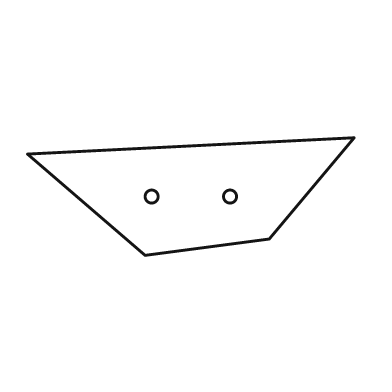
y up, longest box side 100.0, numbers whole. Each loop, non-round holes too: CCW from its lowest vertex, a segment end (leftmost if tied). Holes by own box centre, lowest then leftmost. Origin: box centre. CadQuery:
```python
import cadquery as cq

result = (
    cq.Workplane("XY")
    .moveTo(-14.0, -18.0)
    .lineTo(24.0, -13.0)
    .lineTo(50.0, 18.0)
    .lineTo(-50.0, 13.0)
    .close()
    .moveTo(-12.0, 0.0)
    .circle(2.0)
    .moveTo(12.0, 0.0)
    .circle(2.0)
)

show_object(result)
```